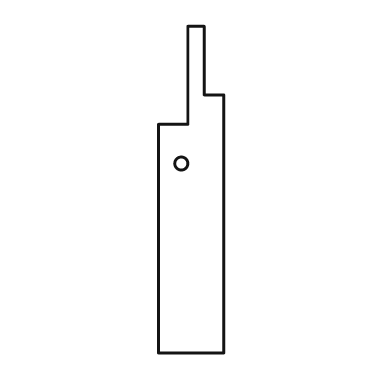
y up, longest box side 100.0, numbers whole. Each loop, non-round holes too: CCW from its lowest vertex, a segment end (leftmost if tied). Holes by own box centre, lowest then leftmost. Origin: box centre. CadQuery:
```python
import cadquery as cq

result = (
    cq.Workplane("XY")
    .moveTo(-10.0, -50.0)
    .lineTo(10.0, -50.0)
    .lineTo(10.0, 29.0)
    .lineTo(4.0, 29.0)
    .lineTo(4.0, 50.0)
    .lineTo(-1.0, 50.0)
    .lineTo(-1.0, 20.0)
    .lineTo(-10.0, 20.0)
    .close()
    .moveTo(-3.0, 8.0)
    .circle(2.0)
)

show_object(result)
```